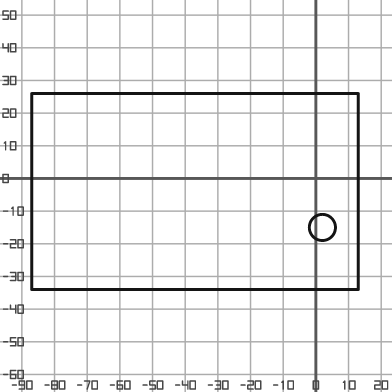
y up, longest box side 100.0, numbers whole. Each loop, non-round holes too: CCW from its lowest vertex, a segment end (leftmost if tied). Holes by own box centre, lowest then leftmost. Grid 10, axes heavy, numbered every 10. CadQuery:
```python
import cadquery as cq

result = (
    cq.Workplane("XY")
    .moveTo(-87.0, -34.0)
    .lineTo(13.0, -34.0)
    .lineTo(13.0, 26.0)
    .lineTo(-87.0, 26.0)
    .close()
    .moveTo(2.0, -15.0)
    .circle(4.0)
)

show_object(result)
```